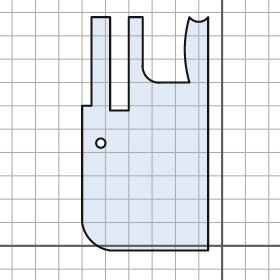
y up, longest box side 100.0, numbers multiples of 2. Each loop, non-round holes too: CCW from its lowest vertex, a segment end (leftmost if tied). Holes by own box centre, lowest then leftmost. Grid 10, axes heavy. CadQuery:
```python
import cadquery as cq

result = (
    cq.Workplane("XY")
    .moveTo(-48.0, -2.0)
    .lineTo(-6.0, -2.0)
    .lineTo(-6.0, 98.0)
    .threePointArc((-10.0, 96.0), (-14.0, 98.0))
    .threePointArc((-16.0, 84.0), (-14.0, 70.0))
    .lineTo(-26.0, 70.0)
    .threePointArc((-32.0, 72.0), (-34.0, 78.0))
    .lineTo(-34.0, 98.0)
    .lineTo(-40.0, 98.0)
    .lineTo(-40.0, 58.0)
    .lineTo(-48.0, 58.0)
    .lineTo(-48.0, 98.0)
    .lineTo(-56.0, 98.0)
    .lineTo(-56.0, 60.0)
    .lineTo(-60.0, 60.0)
    .lineTo(-60.0, 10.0)
    .threePointArc((-56.0, 2.0), (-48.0, -2.0))
    .close()
    .moveTo(-52.0, 44.0)
    .circle(2.0)
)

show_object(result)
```